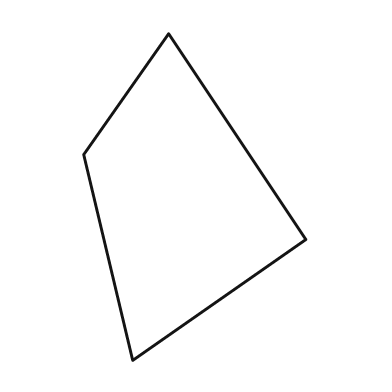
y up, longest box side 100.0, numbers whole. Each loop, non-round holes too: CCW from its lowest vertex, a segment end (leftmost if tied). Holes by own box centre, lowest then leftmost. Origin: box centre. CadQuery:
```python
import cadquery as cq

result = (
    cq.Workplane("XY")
    .moveTo(-19.0, -50.0)
    .lineTo(34.0, -13.0)
    .lineTo(-8.0, 50.0)
    .lineTo(-34.0, 13.0)
    .close()
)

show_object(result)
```